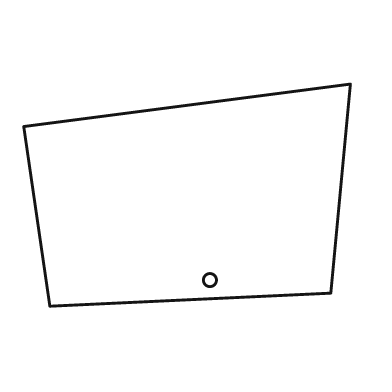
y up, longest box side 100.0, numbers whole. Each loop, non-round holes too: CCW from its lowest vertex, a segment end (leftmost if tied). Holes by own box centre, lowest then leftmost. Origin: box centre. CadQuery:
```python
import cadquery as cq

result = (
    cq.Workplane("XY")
    .moveTo(-42.0, -34.0)
    .lineTo(44.0, -30.0)
    .lineTo(50.0, 34.0)
    .lineTo(-50.0, 21.0)
    .close()
    .moveTo(7.0, -26.0)
    .circle(2.0)
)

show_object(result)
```